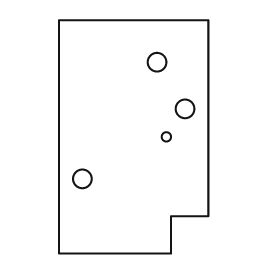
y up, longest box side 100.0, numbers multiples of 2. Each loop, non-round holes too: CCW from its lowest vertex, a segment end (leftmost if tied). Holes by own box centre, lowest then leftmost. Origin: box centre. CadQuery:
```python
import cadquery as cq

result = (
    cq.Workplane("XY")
    .moveTo(-32.0, -50.0)
    .lineTo(16.0, -50.0)
    .lineTo(16.0, -34.0)
    .lineTo(32.0, -34.0)
    .lineTo(32.0, 50.0)
    .lineTo(-32.0, 50.0)
    .close()
    .moveTo(-22.0, -18.0)
    .circle(4.0)
    .moveTo(14.0, 0.0)
    .circle(2.0)
    .moveTo(22.0, 12.0)
    .circle(4.0)
    .moveTo(10.0, 32.0)
    .circle(4.0)
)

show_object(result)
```